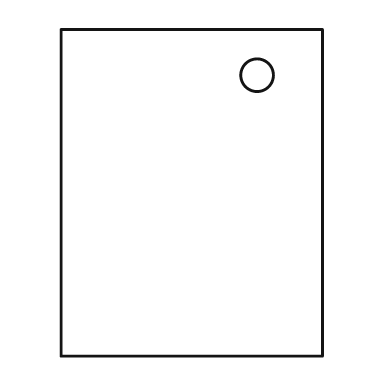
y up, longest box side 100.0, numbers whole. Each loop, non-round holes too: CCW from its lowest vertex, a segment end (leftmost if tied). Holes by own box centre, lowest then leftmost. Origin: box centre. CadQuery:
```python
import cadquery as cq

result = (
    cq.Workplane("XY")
    .moveTo(-40.0, -50.0)
    .lineTo(40.0, -50.0)
    .lineTo(40.0, 50.0)
    .lineTo(-40.0, 50.0)
    .close()
    .moveTo(20.0, 36.0)
    .circle(5.0)
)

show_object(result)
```